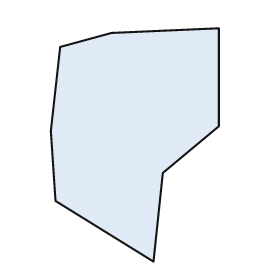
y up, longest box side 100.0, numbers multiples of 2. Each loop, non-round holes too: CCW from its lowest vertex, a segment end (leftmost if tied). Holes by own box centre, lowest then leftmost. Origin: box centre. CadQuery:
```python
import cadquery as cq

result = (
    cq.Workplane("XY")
    .moveTo(8.0, -50.0)
    .lineTo(12.0, -12.0)
    .lineTo(36.0, 8.0)
    .lineTo(36.0, 50.0)
    .lineTo(-10.0, 48.0)
    .lineTo(-32.0, 42.0)
    .lineTo(-36.0, 6.0)
    .lineTo(-34.0, -24.0)
    .close()
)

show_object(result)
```